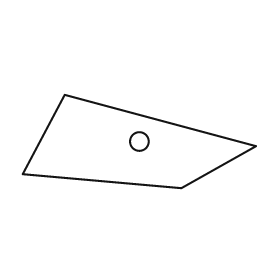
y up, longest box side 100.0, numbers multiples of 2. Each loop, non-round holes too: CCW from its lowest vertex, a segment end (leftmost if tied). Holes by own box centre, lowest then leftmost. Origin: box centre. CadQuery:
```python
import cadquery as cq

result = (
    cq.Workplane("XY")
    .moveTo(18.0, -20.0)
    .lineTo(50.0, -2.0)
    .lineTo(-32.0, 20.0)
    .lineTo(-50.0, -14.0)
    .close()
    .moveTo(0.0, 0.0)
    .circle(4.0)
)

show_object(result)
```